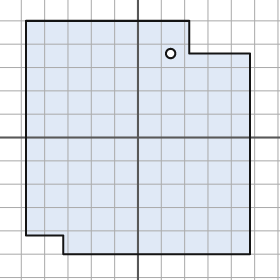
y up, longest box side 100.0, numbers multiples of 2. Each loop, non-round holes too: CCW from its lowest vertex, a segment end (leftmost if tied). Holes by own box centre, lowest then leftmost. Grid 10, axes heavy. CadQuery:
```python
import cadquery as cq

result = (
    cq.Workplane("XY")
    .moveTo(-32.0, -50.0)
    .lineTo(48.0, -50.0)
    .lineTo(48.0, 36.0)
    .lineTo(22.0, 36.0)
    .lineTo(22.0, 50.0)
    .lineTo(-48.0, 50.0)
    .lineTo(-48.0, -42.0)
    .lineTo(-32.0, -42.0)
    .close()
    .moveTo(14.0, 36.0)
    .circle(2.0)
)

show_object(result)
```